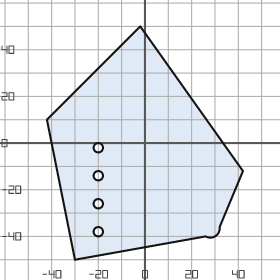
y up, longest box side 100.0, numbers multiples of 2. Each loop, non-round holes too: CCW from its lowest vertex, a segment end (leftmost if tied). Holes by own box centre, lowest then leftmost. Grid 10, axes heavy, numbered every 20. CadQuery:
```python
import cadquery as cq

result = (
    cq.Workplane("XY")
    .moveTo(-30.0, -50.0)
    .lineTo(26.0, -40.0)
    .threePointArc((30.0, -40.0), (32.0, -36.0))
    .lineTo(42.0, -12.0)
    .lineTo(-2.0, 50.0)
    .lineTo(-42.0, 10.0)
    .close()
    .moveTo(-20.0, -38.0)
    .circle(2.0)
    .moveTo(-20.0, -26.0)
    .circle(2.0)
    .moveTo(-20.0, -14.0)
    .circle(2.0)
    .moveTo(-20.0, -2.0)
    .circle(2.0)
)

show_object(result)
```